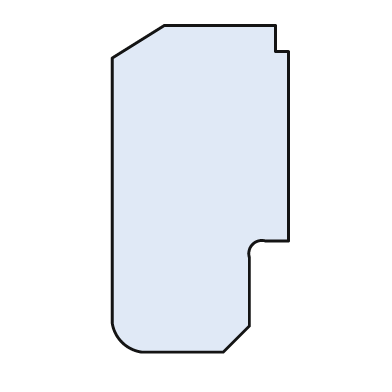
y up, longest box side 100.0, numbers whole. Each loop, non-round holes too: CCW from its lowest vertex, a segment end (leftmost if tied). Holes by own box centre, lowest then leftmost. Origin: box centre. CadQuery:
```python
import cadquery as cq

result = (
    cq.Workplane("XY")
    .moveTo(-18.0, -50.0)
    .lineTo(7.0, -50.0)
    .lineTo(15.0, -42.0)
    .lineTo(15.0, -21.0)
    .threePointArc((16.0, -17.0), (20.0, -16.0))
    .lineTo(27.0, -16.0)
    .lineTo(27.0, 42.0)
    .lineTo(23.0, 42.0)
    .lineTo(23.0, 50.0)
    .lineTo(-11.0, 50.0)
    .lineTo(-27.0, 40.0)
    .lineTo(-27.0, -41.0)
    .threePointArc((-24.0, -47.0), (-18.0, -50.0))
    .close()
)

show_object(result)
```